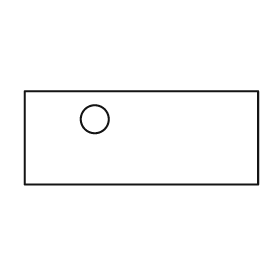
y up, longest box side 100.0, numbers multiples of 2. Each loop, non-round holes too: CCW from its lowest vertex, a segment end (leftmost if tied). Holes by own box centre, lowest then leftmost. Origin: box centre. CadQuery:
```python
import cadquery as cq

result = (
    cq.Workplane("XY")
    .moveTo(-50.0, -20.0)
    .lineTo(50.0, -20.0)
    .lineTo(50.0, 20.0)
    .lineTo(-50.0, 20.0)
    .close()
    .moveTo(-20.0, 8.0)
    .circle(6.0)
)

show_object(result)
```